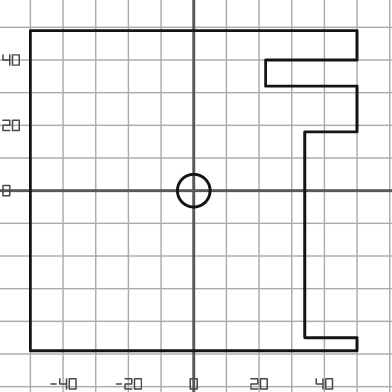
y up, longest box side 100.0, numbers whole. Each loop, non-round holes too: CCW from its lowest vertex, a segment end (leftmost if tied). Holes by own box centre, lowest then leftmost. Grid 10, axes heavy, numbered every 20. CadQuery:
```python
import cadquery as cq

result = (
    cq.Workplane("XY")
    .moveTo(-50.0, -49.0)
    .lineTo(50.0, -49.0)
    .lineTo(50.0, -45.0)
    .lineTo(34.0, -45.0)
    .lineTo(34.0, 18.0)
    .lineTo(50.0, 18.0)
    .lineTo(50.0, 32.0)
    .lineTo(22.0, 32.0)
    .lineTo(22.0, 40.0)
    .lineTo(50.0, 40.0)
    .lineTo(50.0, 49.0)
    .lineTo(-50.0, 49.0)
    .close()
    .moveTo(0.0, 0.0)
    .circle(5.0)
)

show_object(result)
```